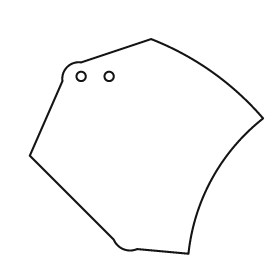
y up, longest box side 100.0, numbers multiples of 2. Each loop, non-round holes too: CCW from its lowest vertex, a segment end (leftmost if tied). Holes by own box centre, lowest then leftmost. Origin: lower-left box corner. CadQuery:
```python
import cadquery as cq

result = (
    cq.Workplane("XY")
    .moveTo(68.0, 0.0)
    .threePointArc((78.0, 32.0), (100.0, 58.0))
    .threePointArc((78.0, 78.0), (52.0, 92.0))
    .lineTo(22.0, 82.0)
    .threePointArc((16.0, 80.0), (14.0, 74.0))
    .lineTo(0.0, 42.0)
    .lineTo(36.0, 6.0)
    .threePointArc((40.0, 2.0), (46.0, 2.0))
    .close()
    .moveTo(22.0, 76.0)
    .circle(2.0)
    .moveTo(34.0, 76.0)
    .circle(2.0)
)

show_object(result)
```